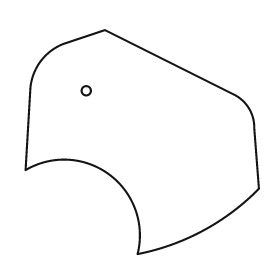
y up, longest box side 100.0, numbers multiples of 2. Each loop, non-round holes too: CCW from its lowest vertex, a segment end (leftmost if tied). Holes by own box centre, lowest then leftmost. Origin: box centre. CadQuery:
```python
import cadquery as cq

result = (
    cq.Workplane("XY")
    .moveTo(-2.0, -48.0)
    .threePointArc((26.0, -38.0), (50.0, -20.0))
    .lineTo(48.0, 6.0)
    .threePointArc((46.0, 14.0), (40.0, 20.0))
    .lineTo(-16.0, 48.0)
    .lineTo(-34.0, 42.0)
    .threePointArc((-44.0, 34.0), (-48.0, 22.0))
    .lineTo(-50.0, -12.0)
    .threePointArc((-14.0, -14.0), (-2.0, -48.0))
    .close()
    .moveTo(-24.0, 22.0)
    .circle(2.0)
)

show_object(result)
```